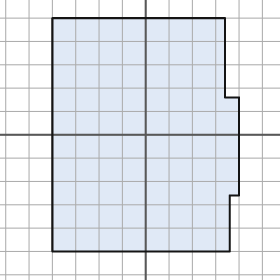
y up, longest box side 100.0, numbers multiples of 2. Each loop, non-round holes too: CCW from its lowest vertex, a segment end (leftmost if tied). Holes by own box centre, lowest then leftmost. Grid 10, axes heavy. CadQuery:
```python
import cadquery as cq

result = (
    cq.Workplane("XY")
    .moveTo(-40.0, -50.0)
    .lineTo(36.0, -50.0)
    .lineTo(36.0, -26.0)
    .lineTo(40.0, -26.0)
    .lineTo(40.0, 16.0)
    .lineTo(34.0, 16.0)
    .lineTo(34.0, 50.0)
    .lineTo(-40.0, 50.0)
    .close()
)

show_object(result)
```